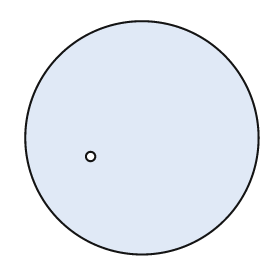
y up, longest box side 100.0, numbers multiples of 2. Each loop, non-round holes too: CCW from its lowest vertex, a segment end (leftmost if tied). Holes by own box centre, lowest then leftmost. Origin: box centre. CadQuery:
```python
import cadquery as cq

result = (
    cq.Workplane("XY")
    .moveTo(0.0, 0.0)
    .circle(50.0)
    .moveTo(-22.0, -8.0)
    .circle(2.0)
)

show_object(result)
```